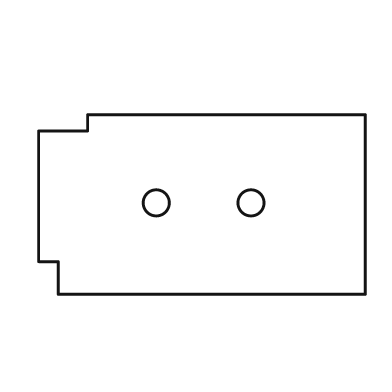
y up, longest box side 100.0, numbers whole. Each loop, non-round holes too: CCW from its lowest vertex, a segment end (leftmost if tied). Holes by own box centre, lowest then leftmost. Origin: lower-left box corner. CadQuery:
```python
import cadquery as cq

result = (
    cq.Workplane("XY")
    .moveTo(6.0, 0.0)
    .lineTo(100.0, 0.0)
    .lineTo(100.0, 55.0)
    .lineTo(15.0, 55.0)
    .lineTo(15.0, 50.0)
    .lineTo(0.0, 50.0)
    .lineTo(0.0, 10.0)
    .lineTo(6.0, 10.0)
    .close()
    .moveTo(36.0, 28.0)
    .circle(4.0)
    .moveTo(65.0, 28.0)
    .circle(4.0)
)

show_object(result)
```